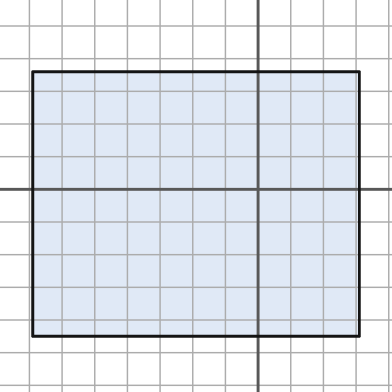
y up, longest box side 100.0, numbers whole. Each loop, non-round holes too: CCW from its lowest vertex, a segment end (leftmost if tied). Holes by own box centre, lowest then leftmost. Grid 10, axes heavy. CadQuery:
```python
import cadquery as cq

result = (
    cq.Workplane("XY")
    .moveTo(-69.0, -45.0)
    .lineTo(31.0, -45.0)
    .lineTo(31.0, 36.0)
    .lineTo(-69.0, 36.0)
    .close()
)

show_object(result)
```